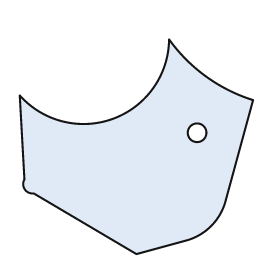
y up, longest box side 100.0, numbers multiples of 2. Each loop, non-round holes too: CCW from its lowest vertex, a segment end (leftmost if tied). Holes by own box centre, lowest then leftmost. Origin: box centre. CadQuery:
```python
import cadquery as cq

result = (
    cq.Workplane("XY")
    .moveTo(0.0, -46.0)
    .lineTo(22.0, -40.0)
    .threePointArc((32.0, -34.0), (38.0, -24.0))
    .lineTo(50.0, 20.0)
    .threePointArc((30.0, 30.0), (14.0, 46.0))
    .threePointArc((-10.0, 12.0), (-50.0, 22.0))
    .lineTo(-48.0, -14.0)
    .threePointArc((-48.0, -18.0), (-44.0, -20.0))
    .close()
    .moveTo(26.0, 6.0)
    .circle(4.0)
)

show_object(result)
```